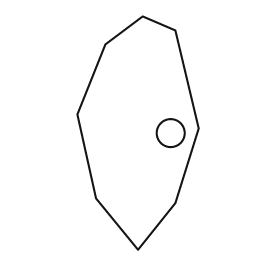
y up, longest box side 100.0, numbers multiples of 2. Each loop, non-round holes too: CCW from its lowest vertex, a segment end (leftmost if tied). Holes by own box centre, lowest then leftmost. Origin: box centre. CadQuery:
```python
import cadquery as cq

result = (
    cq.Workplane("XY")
    .moveTo(0.0, -50.0)
    .lineTo(16.0, -30.0)
    .lineTo(26.0, 2.0)
    .lineTo(16.0, 44.0)
    .lineTo(2.0, 50.0)
    .lineTo(-14.0, 38.0)
    .lineTo(-26.0, 8.0)
    .lineTo(-18.0, -28.0)
    .close()
    .moveTo(14.0, 0.0)
    .circle(6.0)
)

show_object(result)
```